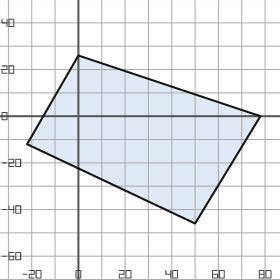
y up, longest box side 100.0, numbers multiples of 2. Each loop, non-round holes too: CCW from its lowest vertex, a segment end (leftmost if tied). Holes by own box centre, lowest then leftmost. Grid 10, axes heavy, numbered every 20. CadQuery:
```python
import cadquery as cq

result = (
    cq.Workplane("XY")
    .moveTo(50.0, -46.0)
    .lineTo(78.0, 0.0)
    .lineTo(0.0, 26.0)
    .lineTo(-22.0, -12.0)
    .close()
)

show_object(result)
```